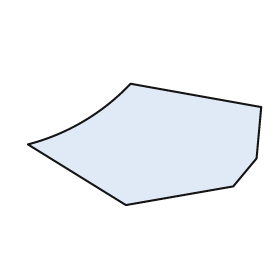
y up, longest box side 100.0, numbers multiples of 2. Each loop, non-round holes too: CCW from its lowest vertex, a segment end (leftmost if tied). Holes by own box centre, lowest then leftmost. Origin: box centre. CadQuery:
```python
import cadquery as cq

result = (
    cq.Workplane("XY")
    .moveTo(-8.0, -26.0)
    .lineTo(38.0, -18.0)
    .lineTo(48.0, -6.0)
    .lineTo(50.0, 16.0)
    .lineTo(-6.0, 26.0)
    .threePointArc((-26.0, 10.0), (-50.0, 0.0))
    .close()
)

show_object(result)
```